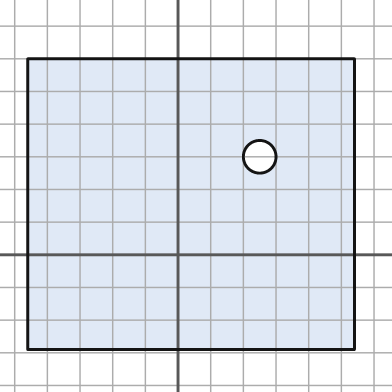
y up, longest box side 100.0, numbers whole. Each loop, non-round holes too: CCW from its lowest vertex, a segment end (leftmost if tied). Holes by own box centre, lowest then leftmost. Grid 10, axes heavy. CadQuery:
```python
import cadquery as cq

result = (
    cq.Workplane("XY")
    .moveTo(-46.0, -29.0)
    .lineTo(54.0, -29.0)
    .lineTo(54.0, 60.0)
    .lineTo(-46.0, 60.0)
    .close()
    .moveTo(25.0, 30.0)
    .circle(5.0)
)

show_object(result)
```